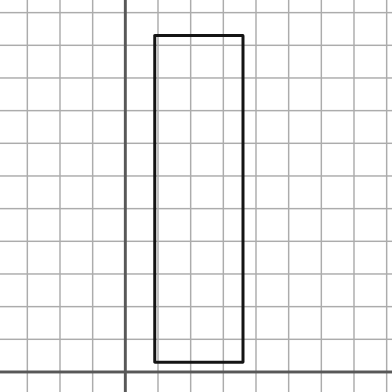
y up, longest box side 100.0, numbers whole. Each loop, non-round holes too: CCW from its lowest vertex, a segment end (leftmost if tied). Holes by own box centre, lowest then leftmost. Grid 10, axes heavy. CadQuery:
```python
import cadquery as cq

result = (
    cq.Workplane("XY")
    .moveTo(9.0, 3.0)
    .lineTo(36.0, 3.0)
    .lineTo(36.0, 103.0)
    .lineTo(9.0, 103.0)
    .close()
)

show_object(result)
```